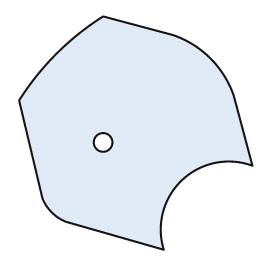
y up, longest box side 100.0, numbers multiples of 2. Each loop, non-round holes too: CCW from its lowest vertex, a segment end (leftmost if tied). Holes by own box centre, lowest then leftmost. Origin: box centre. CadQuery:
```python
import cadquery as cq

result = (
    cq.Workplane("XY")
    .moveTo(12.0, -50.0)
    .threePointArc((20.0, -20.0), (50.0, -14.0))
    .lineTo(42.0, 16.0)
    .threePointArc((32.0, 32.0), (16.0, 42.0))
    .lineTo(-14.0, 50.0)
    .threePointArc((-34.0, 34.0), (-50.0, 14.0))
    .lineTo(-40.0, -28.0)
    .threePointArc((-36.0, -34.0), (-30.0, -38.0))
    .close()
    .moveTo(-14.0, -4.0)
    .circle(4.0)
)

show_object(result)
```